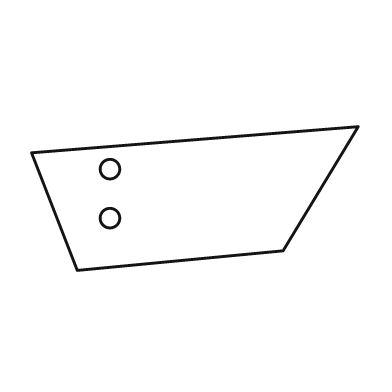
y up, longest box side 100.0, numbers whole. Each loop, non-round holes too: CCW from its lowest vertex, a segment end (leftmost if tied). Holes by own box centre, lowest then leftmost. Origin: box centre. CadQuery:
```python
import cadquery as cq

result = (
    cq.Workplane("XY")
    .moveTo(-36.0, -22.0)
    .lineTo(27.0, -16.0)
    .lineTo(50.0, 22.0)
    .lineTo(-50.0, 14.0)
    .close()
    .moveTo(-26.0, -6.0)
    .circle(3.0)
    .moveTo(-26.0, 9.0)
    .circle(3.0)
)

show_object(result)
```